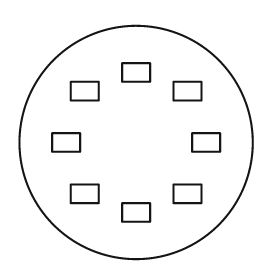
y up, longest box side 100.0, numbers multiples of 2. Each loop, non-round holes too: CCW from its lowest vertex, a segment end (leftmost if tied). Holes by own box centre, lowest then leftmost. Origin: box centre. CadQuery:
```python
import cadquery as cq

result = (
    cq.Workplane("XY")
    .moveTo(0.0, 0.0)
    .circle(50.0)
    .moveTo(-6.0, -34.0)
    .lineTo(6.0, -34.0)
    .lineTo(6.0, -26.0)
    .lineTo(-6.0, -26.0)
    .close()
    .moveTo(-28.0, -26.0)
    .lineTo(-16.0, -26.0)
    .lineTo(-16.0, -18.0)
    .lineTo(-28.0, -18.0)
    .close()
    .moveTo(16.0, -26.0)
    .lineTo(28.0, -26.0)
    .lineTo(28.0, -18.0)
    .lineTo(16.0, -18.0)
    .close()
    .moveTo(-36.0, -4.0)
    .lineTo(-24.0, -4.0)
    .lineTo(-24.0, 4.0)
    .lineTo(-36.0, 4.0)
    .close()
    .moveTo(24.0, -4.0)
    .lineTo(36.0, -4.0)
    .lineTo(36.0, 4.0)
    .lineTo(24.0, 4.0)
    .close()
    .moveTo(-28.0, 18.0)
    .lineTo(-16.0, 18.0)
    .lineTo(-16.0, 26.0)
    .lineTo(-28.0, 26.0)
    .close()
    .moveTo(16.0, 18.0)
    .lineTo(28.0, 18.0)
    .lineTo(28.0, 26.0)
    .lineTo(16.0, 26.0)
    .close()
    .moveTo(-6.0, 26.0)
    .lineTo(6.0, 26.0)
    .lineTo(6.0, 34.0)
    .lineTo(-6.0, 34.0)
    .close()
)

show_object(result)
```